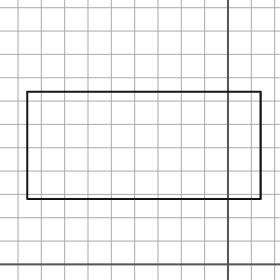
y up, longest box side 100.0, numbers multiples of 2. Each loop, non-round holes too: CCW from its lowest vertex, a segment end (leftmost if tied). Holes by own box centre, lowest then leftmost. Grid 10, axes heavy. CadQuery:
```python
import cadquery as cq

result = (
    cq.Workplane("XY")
    .moveTo(-86.0, 28.0)
    .lineTo(14.0, 28.0)
    .lineTo(14.0, 74.0)
    .lineTo(-86.0, 74.0)
    .close()
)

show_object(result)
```